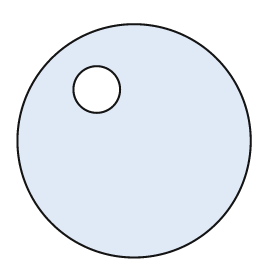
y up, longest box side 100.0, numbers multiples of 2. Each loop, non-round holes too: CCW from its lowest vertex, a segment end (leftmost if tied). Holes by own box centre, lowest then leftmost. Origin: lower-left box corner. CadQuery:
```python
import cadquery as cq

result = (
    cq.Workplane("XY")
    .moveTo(50.0, 50.0)
    .circle(50.0)
    .moveTo(34.0, 72.0)
    .circle(10.0)
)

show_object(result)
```